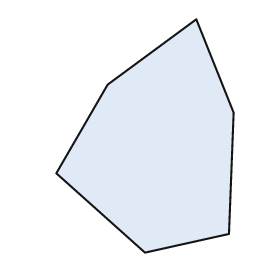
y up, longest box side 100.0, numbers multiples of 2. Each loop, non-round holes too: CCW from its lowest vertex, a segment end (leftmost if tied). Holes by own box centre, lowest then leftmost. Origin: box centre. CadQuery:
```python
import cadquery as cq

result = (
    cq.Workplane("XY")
    .moveTo(0.0, -50.0)
    .lineTo(36.0, -42.0)
    .lineTo(38.0, 10.0)
    .lineTo(22.0, 50.0)
    .lineTo(-16.0, 22.0)
    .lineTo(-38.0, -16.0)
    .close()
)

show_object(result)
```